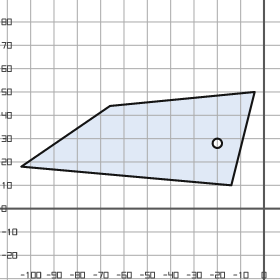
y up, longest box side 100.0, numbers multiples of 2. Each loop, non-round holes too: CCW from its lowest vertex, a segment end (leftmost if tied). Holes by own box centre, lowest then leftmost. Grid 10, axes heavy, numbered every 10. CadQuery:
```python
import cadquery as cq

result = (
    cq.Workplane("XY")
    .moveTo(-14.0, 10.0)
    .lineTo(-4.0, 50.0)
    .lineTo(-66.0, 44.0)
    .lineTo(-104.0, 18.0)
    .close()
    .moveTo(-20.0, 28.0)
    .circle(2.0)
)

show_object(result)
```